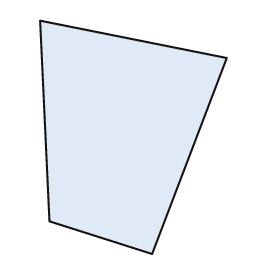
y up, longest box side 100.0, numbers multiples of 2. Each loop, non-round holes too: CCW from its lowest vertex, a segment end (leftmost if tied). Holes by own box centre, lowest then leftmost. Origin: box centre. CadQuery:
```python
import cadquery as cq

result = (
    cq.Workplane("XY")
    .moveTo(8.0, -50.0)
    .lineTo(40.0, 34.0)
    .lineTo(-40.0, 50.0)
    .lineTo(-36.0, -36.0)
    .close()
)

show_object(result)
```